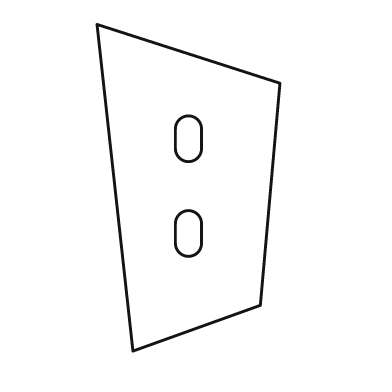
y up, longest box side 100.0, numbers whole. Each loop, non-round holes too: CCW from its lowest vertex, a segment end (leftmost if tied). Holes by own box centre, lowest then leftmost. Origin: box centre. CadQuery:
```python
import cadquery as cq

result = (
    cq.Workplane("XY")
    .moveTo(-17.0, -50.0)
    .lineTo(22.0, -36.0)
    .lineTo(28.0, 32.0)
    .lineTo(-28.0, 50.0)
    .close()
    .moveTo(-4.0, -17.0)
    .threePointArc((0.0, -21.0), (4.0, -17.0))
    .lineTo(4.0, -11.0)
    .threePointArc((0.0, -7.0), (-4.0, -11.0))
    .close()
    .moveTo(-4.0, 12.0)
    .threePointArc((0.0, 8.0), (4.0, 12.0))
    .lineTo(4.0, 18.0)
    .threePointArc((0.0, 22.0), (-4.0, 18.0))
    .close()
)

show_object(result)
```